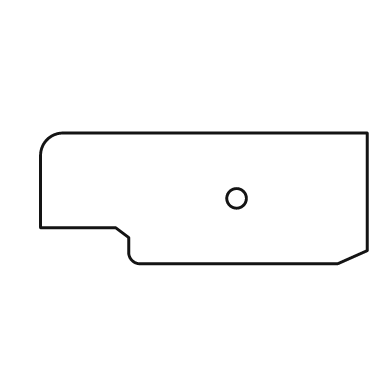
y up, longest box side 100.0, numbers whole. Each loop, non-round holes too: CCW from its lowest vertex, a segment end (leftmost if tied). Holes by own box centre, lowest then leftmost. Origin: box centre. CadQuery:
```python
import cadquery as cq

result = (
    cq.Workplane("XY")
    .moveTo(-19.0, -20.0)
    .lineTo(41.0, -20.0)
    .lineTo(50.0, -16.0)
    .lineTo(50.0, 20.0)
    .lineTo(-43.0, 20.0)
    .threePointArc((-48.0, 18.0), (-50.0, 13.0))
    .lineTo(-50.0, -9.0)
    .lineTo(-27.0, -9.0)
    .lineTo(-23.0, -12.0)
    .lineTo(-23.0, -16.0)
    .threePointArc((-22.0, -19.0), (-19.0, -20.0))
    .close()
    .moveTo(10.0, 0.0)
    .circle(3.0)
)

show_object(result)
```